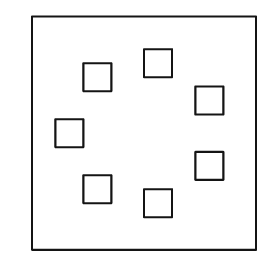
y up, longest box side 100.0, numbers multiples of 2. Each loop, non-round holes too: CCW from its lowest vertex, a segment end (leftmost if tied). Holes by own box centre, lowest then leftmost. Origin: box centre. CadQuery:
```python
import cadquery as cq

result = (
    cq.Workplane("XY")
    .moveTo(-48.0, -50.0)
    .lineTo(48.0, -50.0)
    .lineTo(48.0, 50.0)
    .lineTo(-48.0, 50.0)
    .close()
    .moveTo(0.0, -36.0)
    .lineTo(12.0, -36.0)
    .lineTo(12.0, -24.0)
    .lineTo(0.0, -24.0)
    .close()
    .moveTo(-26.0, -30.0)
    .lineTo(-14.0, -30.0)
    .lineTo(-14.0, -18.0)
    .lineTo(-26.0, -18.0)
    .close()
    .moveTo(22.0, -20.0)
    .lineTo(34.0, -20.0)
    .lineTo(34.0, -8.0)
    .lineTo(22.0, -8.0)
    .close()
    .moveTo(-38.0, -6.0)
    .lineTo(-26.0, -6.0)
    .lineTo(-26.0, 6.0)
    .lineTo(-38.0, 6.0)
    .close()
    .moveTo(22.0, 8.0)
    .lineTo(34.0, 8.0)
    .lineTo(34.0, 20.0)
    .lineTo(22.0, 20.0)
    .close()
    .moveTo(-26.0, 18.0)
    .lineTo(-14.0, 18.0)
    .lineTo(-14.0, 30.0)
    .lineTo(-26.0, 30.0)
    .close()
    .moveTo(0.0, 24.0)
    .lineTo(12.0, 24.0)
    .lineTo(12.0, 36.0)
    .lineTo(0.0, 36.0)
    .close()
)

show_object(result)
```